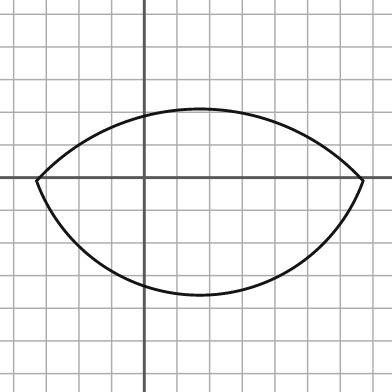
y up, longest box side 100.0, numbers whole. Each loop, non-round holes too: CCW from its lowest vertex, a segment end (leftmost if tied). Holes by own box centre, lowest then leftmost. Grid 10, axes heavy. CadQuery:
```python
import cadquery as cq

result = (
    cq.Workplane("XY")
    .moveTo(-33.0, -1.0)
    .threePointArc((17.0, -36.0), (67.0, -1.0))
    .threePointArc((17.0, 21.0), (-33.0, -1.0))
    .close()
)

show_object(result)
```